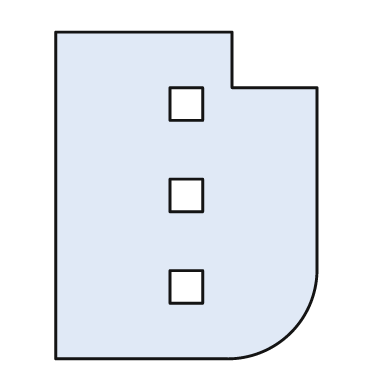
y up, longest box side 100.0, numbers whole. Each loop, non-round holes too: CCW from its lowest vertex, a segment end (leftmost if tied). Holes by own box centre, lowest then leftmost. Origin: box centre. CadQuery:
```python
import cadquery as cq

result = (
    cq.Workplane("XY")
    .moveTo(-40.0, -50.0)
    .lineTo(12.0, -50.0)
    .threePointArc((32.0, -42.0), (40.0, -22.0))
    .lineTo(40.0, 33.0)
    .lineTo(14.0, 33.0)
    .lineTo(14.0, 50.0)
    .lineTo(-40.0, 50.0)
    .close()
    .moveTo(-5.0, -33.0)
    .lineTo(5.0, -33.0)
    .lineTo(5.0, -23.0)
    .lineTo(-5.0, -23.0)
    .close()
    .moveTo(-5.0, -5.0)
    .lineTo(5.0, -5.0)
    .lineTo(5.0, 5.0)
    .lineTo(-5.0, 5.0)
    .close()
    .moveTo(-5.0, 23.0)
    .lineTo(5.0, 23.0)
    .lineTo(5.0, 33.0)
    .lineTo(-5.0, 33.0)
    .close()
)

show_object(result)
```